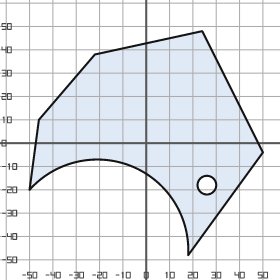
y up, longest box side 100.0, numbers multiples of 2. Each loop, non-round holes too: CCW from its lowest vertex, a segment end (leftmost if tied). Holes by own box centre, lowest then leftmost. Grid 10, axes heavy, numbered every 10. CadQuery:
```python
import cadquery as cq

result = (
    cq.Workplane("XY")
    .moveTo(18.0, -48.0)
    .lineTo(50.0, -4.0)
    .lineTo(24.0, 48.0)
    .lineTo(-22.0, 38.0)
    .lineTo(-46.0, 10.0)
    .lineTo(-50.0, -20.0)
    .threePointArc((-6.0, -10.0), (18.0, -48.0))
    .close()
    .moveTo(26.0, -18.0)
    .circle(4.0)
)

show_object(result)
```